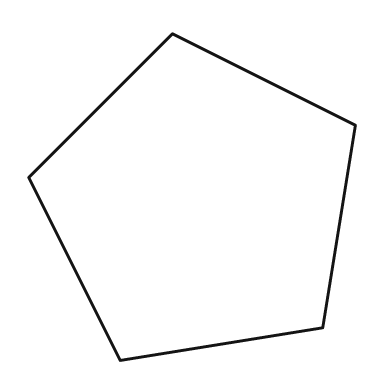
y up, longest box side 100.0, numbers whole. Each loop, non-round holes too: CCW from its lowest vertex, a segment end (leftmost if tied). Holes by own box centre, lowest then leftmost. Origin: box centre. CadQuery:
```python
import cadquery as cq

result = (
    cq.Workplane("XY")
    .moveTo(-22.0, -50.0)
    .lineTo(40.0, -40.0)
    .lineTo(50.0, 22.0)
    .lineTo(-6.0, 50.0)
    .lineTo(-50.0, 6.0)
    .close()
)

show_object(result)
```